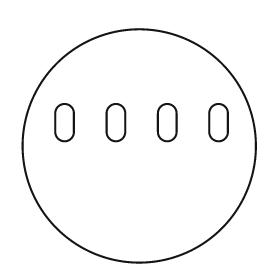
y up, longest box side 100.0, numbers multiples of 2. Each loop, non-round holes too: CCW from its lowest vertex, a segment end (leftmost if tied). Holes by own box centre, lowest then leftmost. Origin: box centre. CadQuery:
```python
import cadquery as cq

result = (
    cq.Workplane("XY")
    .moveTo(0.0, 0.0)
    .circle(50.0)
    .moveTo(-36.0, 6.0)
    .threePointArc((-32.0, 2.0), (-28.0, 6.0))
    .lineTo(-28.0, 14.0)
    .threePointArc((-32.0, 18.0), (-36.0, 14.0))
    .close()
    .moveTo(-14.0, 6.0)
    .threePointArc((-10.0, 2.0), (-6.0, 6.0))
    .lineTo(-6.0, 14.0)
    .threePointArc((-10.0, 18.0), (-14.0, 14.0))
    .close()
    .moveTo(8.0, 6.0)
    .threePointArc((12.0, 2.0), (16.0, 6.0))
    .lineTo(16.0, 14.0)
    .threePointArc((12.0, 18.0), (8.0, 14.0))
    .close()
    .moveTo(30.0, 6.0)
    .threePointArc((34.0, 2.0), (38.0, 6.0))
    .lineTo(38.0, 14.0)
    .threePointArc((34.0, 18.0), (30.0, 14.0))
    .close()
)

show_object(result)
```